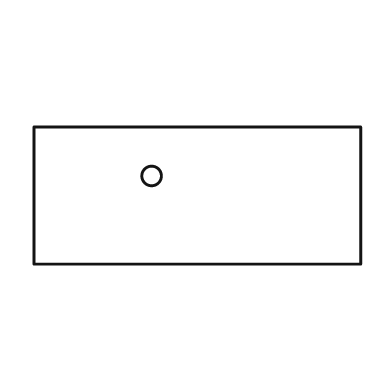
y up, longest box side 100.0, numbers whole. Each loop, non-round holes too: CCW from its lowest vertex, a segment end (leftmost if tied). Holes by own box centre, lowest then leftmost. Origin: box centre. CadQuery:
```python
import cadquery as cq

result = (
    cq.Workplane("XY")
    .moveTo(-50.0, -21.0)
    .lineTo(50.0, -21.0)
    .lineTo(50.0, 21.0)
    .lineTo(-50.0, 21.0)
    .close()
    .moveTo(-14.0, 6.0)
    .circle(3.0)
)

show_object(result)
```